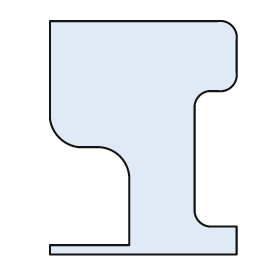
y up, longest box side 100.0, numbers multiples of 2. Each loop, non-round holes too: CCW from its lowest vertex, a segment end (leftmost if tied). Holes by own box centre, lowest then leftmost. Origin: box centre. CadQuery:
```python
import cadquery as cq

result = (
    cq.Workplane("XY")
    .moveTo(-40.0, -50.0)
    .lineTo(40.0, -50.0)
    .lineTo(40.0, -38.0)
    .lineTo(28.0, -38.0)
    .threePointArc((24.0, -36.0), (22.0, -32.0))
    .lineTo(22.0, 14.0)
    .threePointArc((24.0, 18.0), (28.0, 20.0))
    .lineTo(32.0, 20.0)
    .threePointArc((38.0, 22.0), (40.0, 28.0))
    .lineTo(40.0, 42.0)
    .threePointArc((38.0, 48.0), (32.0, 50.0))
    .lineTo(-40.0, 50.0)
    .lineTo(-40.0, 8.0)
    .threePointArc((-36.0, 0.0), (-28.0, -4.0))
    .lineTo(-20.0, -4.0)
    .threePointArc((-10.0, -8.0), (-6.0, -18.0))
    .lineTo(-6.0, -46.0)
    .lineTo(-40.0, -46.0)
    .close()
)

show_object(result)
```